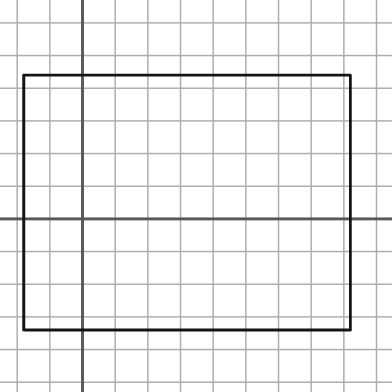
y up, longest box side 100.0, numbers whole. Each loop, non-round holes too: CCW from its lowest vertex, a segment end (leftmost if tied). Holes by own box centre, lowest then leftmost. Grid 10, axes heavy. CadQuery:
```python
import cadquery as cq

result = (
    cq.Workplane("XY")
    .moveTo(-18.0, -34.0)
    .lineTo(82.0, -34.0)
    .lineTo(82.0, 44.0)
    .lineTo(-18.0, 44.0)
    .close()
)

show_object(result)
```